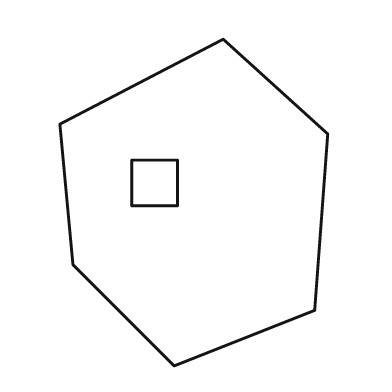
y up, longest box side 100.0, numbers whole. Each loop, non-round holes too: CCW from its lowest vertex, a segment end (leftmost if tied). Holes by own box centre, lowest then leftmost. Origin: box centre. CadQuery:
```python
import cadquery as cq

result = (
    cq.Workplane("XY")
    .moveTo(-6.0, -50.0)
    .lineTo(37.0, -33.0)
    .lineTo(41.0, 21.0)
    .lineTo(9.0, 50.0)
    .lineTo(-41.0, 24.0)
    .lineTo(-37.0, -19.0)
    .close()
    .moveTo(-19.0, -1.0)
    .lineTo(-5.0, -1.0)
    .lineTo(-5.0, 13.0)
    .lineTo(-19.0, 13.0)
    .close()
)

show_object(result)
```